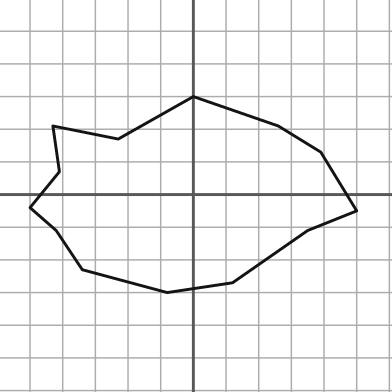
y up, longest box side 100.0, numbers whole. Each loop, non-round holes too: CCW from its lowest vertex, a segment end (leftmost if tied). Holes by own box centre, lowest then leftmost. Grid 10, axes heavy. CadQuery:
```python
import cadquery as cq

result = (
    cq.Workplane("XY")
    .moveTo(-8.0, -30.0)
    .lineTo(12.0, -27.0)
    .lineTo(35.0, -11.0)
    .lineTo(50.0, -5.0)
    .lineTo(39.0, 13.0)
    .lineTo(26.0, 21.0)
    .lineTo(0.0, 30.0)
    .lineTo(-23.0, 17.0)
    .lineTo(-43.0, 21.0)
    .lineTo(-41.0, 7.0)
    .lineTo(-50.0, -4.0)
    .lineTo(-42.0, -11.0)
    .lineTo(-34.0, -23.0)
    .close()
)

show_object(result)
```